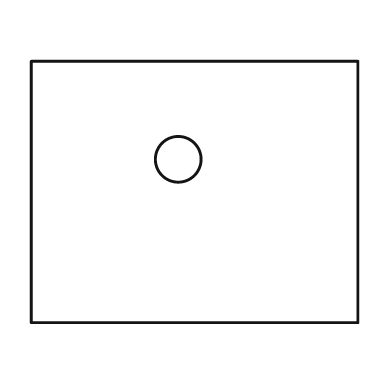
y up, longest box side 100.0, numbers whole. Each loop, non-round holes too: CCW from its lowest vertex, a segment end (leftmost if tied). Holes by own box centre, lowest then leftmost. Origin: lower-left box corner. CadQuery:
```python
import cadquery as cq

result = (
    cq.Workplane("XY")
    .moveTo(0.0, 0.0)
    .lineTo(100.0, 0.0)
    .lineTo(100.0, 80.0)
    .lineTo(0.0, 80.0)
    .close()
    .moveTo(45.0, 50.0)
    .circle(7.0)
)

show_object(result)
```